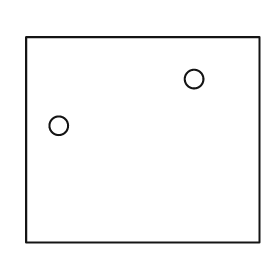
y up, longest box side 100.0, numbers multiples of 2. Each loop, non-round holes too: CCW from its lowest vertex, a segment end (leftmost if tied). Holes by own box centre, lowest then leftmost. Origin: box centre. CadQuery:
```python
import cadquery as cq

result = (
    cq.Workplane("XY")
    .moveTo(-50.0, -44.0)
    .lineTo(50.0, -44.0)
    .lineTo(50.0, 44.0)
    .lineTo(-50.0, 44.0)
    .close()
    .moveTo(-36.0, 6.0)
    .circle(4.0)
    .moveTo(22.0, 26.0)
    .circle(4.0)
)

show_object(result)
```